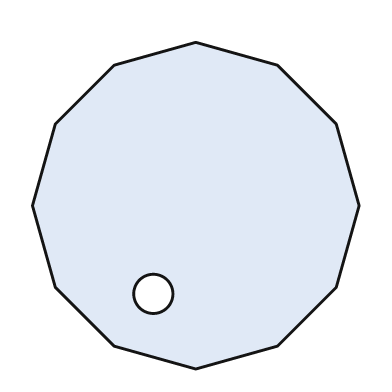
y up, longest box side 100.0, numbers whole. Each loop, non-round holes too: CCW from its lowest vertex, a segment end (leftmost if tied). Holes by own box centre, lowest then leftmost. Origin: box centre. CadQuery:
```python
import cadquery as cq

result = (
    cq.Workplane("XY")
    .moveTo(0.0, -50.0)
    .lineTo(25.0, -43.0)
    .lineTo(43.0, -25.0)
    .lineTo(50.0, 0.0)
    .lineTo(43.0, 25.0)
    .lineTo(25.0, 43.0)
    .lineTo(0.0, 50.0)
    .lineTo(-25.0, 43.0)
    .lineTo(-43.0, 25.0)
    .lineTo(-50.0, 0.0)
    .lineTo(-43.0, -25.0)
    .lineTo(-25.0, -43.0)
    .close()
    .moveTo(-13.0, -27.0)
    .circle(6.0)
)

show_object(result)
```